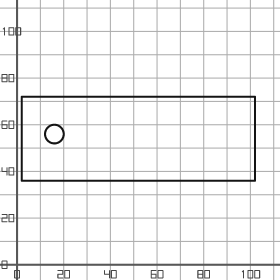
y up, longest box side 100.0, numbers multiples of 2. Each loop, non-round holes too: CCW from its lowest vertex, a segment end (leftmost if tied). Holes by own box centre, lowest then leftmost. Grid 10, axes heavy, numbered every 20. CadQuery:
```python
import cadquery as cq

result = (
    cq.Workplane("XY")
    .moveTo(2.0, 36.0)
    .lineTo(102.0, 36.0)
    .lineTo(102.0, 72.0)
    .lineTo(2.0, 72.0)
    .close()
    .moveTo(16.0, 56.0)
    .circle(4.0)
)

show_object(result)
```